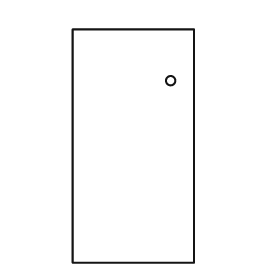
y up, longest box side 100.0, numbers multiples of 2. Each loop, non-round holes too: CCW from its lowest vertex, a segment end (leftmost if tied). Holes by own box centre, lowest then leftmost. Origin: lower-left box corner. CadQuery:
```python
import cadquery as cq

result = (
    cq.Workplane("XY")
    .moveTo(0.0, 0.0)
    .lineTo(52.0, 0.0)
    .lineTo(52.0, 100.0)
    .lineTo(0.0, 100.0)
    .close()
    .moveTo(42.0, 78.0)
    .circle(2.0)
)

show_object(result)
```